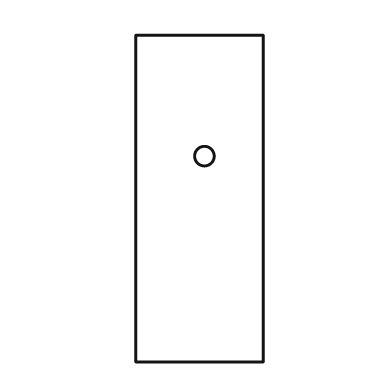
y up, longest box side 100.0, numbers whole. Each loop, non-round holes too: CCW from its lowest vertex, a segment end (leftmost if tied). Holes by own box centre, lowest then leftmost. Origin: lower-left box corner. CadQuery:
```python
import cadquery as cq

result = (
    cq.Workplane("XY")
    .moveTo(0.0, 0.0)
    .lineTo(39.0, 0.0)
    .lineTo(39.0, 100.0)
    .lineTo(0.0, 100.0)
    .close()
    .moveTo(21.0, 63.0)
    .circle(3.0)
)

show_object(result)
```